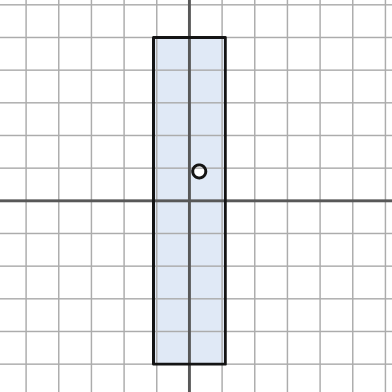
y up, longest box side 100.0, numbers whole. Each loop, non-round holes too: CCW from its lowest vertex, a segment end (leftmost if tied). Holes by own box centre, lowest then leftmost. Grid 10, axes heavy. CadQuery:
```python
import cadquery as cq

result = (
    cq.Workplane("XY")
    .moveTo(-11.0, -50.0)
    .lineTo(11.0, -50.0)
    .lineTo(11.0, 50.0)
    .lineTo(-11.0, 50.0)
    .close()
    .moveTo(3.0, 9.0)
    .circle(2.0)
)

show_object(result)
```